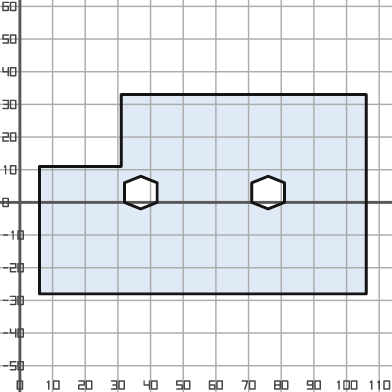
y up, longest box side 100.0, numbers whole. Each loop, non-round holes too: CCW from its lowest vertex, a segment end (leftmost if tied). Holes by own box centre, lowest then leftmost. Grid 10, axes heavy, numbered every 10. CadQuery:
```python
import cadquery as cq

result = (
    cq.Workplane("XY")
    .moveTo(6.0, -28.0)
    .lineTo(106.0, -28.0)
    .lineTo(106.0, 33.0)
    .lineTo(31.0, 33.0)
    .lineTo(31.0, 11.0)
    .lineTo(6.0, 11.0)
    .close()
    .moveTo(37.0, -2.0)
    .lineTo(42.0, 0.0)
    .lineTo(42.0, 6.0)
    .lineTo(37.0, 8.0)
    .lineTo(32.0, 6.0)
    .lineTo(32.0, 0.0)
    .close()
    .moveTo(76.0, -2.0)
    .lineTo(81.0, 0.0)
    .lineTo(81.0, 6.0)
    .lineTo(76.0, 8.0)
    .lineTo(71.0, 6.0)
    .lineTo(71.0, 0.0)
    .close()
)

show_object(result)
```